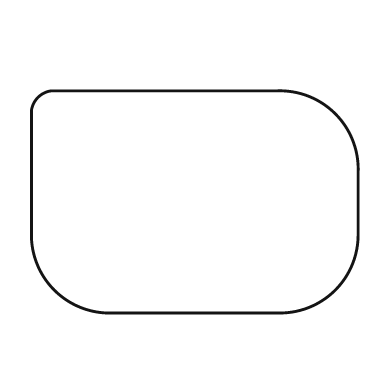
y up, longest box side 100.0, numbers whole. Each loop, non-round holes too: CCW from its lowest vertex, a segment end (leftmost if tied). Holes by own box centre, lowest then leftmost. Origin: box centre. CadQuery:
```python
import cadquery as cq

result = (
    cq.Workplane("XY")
    .moveTo(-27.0, -34.0)
    .lineTo(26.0, -34.0)
    .threePointArc((43.0, -27.0), (50.0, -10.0))
    .lineTo(50.0, 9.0)
    .threePointArc((43.0, 27.0), (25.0, 34.0))
    .lineTo(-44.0, 34.0)
    .threePointArc((-48.0, 32.0), (-50.0, 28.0))
    .lineTo(-50.0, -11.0)
    .threePointArc((-43.0, -27.0), (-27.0, -34.0))
    .close()
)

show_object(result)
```